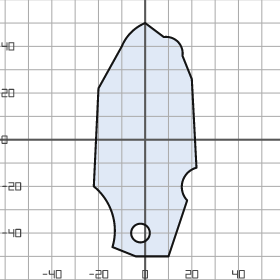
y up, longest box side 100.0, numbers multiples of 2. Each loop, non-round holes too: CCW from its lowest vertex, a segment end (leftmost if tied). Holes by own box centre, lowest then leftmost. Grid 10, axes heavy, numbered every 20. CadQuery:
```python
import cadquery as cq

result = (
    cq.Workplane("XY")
    .moveTo(-4.0, -50.0)
    .lineTo(10.0, -50.0)
    .lineTo(18.0, -26.0)
    .threePointArc((16.0, -18.0), (22.0, -12.0))
    .lineTo(20.0, 26.0)
    .lineTo(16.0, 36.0)
    .threePointArc((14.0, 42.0), (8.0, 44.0))
    .lineTo(0.0, 50.0)
    .threePointArc((-6.0, 46.0), (-10.0, 40.0))
    .lineTo(-20.0, 22.0)
    .lineTo(-22.0, -20.0)
    .threePointArc((-14.0, -32.0), (-14.0, -46.0))
    .close()
    .moveTo(-2.0, -40.0)
    .circle(4.0)
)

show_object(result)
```